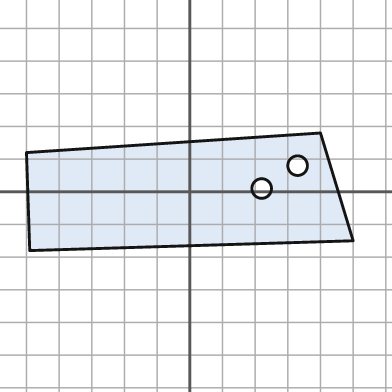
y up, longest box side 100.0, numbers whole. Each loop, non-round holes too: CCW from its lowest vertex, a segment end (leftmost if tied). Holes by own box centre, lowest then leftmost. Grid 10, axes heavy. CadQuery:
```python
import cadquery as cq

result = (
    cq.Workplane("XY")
    .moveTo(-49.0, -18.0)
    .lineTo(50.0, -15.0)
    .lineTo(40.0, 18.0)
    .lineTo(-50.0, 12.0)
    .close()
    .moveTo(22.0, 1.0)
    .circle(3.0)
    .moveTo(33.0, 8.0)
    .circle(3.0)
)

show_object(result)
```